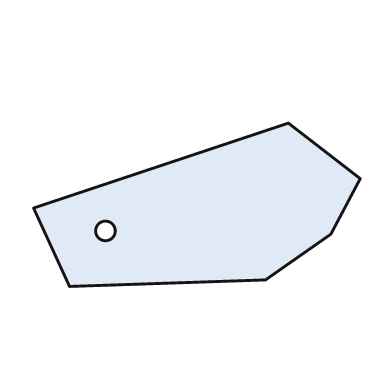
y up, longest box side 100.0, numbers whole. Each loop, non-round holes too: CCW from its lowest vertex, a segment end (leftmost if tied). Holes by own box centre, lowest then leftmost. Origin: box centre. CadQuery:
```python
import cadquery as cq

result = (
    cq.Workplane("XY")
    .moveTo(-39.0, -25.0)
    .lineTo(21.0, -23.0)
    .lineTo(41.0, -9.0)
    .lineTo(50.0, 8.0)
    .lineTo(28.0, 25.0)
    .lineTo(-50.0, -1.0)
    .close()
    .moveTo(-28.0, -8.0)
    .circle(3.0)
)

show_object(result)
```